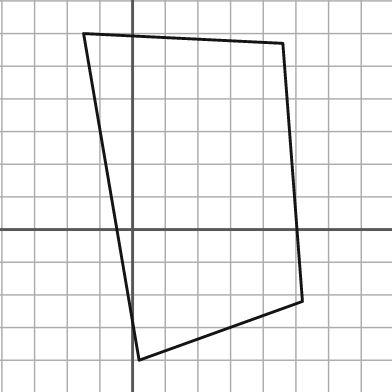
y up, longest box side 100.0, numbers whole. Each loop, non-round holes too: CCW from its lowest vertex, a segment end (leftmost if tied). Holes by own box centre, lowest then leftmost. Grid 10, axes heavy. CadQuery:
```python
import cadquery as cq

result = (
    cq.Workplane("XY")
    .moveTo(2.0, -40.0)
    .lineTo(52.0, -22.0)
    .lineTo(46.0, 57.0)
    .lineTo(-15.0, 60.0)
    .close()
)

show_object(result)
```